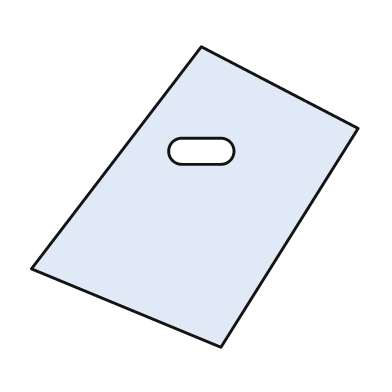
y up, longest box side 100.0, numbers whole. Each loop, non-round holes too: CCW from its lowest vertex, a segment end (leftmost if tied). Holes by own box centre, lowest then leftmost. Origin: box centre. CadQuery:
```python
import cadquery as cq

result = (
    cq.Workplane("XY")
    .moveTo(8.0, -46.0)
    .lineTo(50.0, 21.0)
    .lineTo(2.0, 46.0)
    .lineTo(-50.0, -22.0)
    .close()
    .moveTo(-4.0, 10.0)
    .lineTo(8.0, 10.0)
    .threePointArc((12.0, 14.0), (8.0, 18.0))
    .lineTo(-4.0, 18.0)
    .threePointArc((-8.0, 14.0), (-4.0, 10.0))
    .close()
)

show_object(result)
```